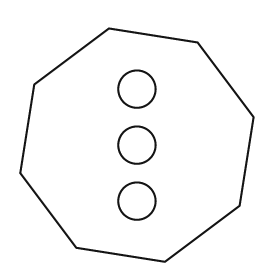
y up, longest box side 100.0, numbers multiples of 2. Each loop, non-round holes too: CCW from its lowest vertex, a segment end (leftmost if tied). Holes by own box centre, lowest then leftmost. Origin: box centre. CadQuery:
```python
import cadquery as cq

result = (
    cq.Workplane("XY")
    .moveTo(12.0, -50.0)
    .lineTo(44.0, -26.0)
    .lineTo(50.0, 12.0)
    .lineTo(26.0, 44.0)
    .lineTo(-12.0, 50.0)
    .lineTo(-44.0, 26.0)
    .lineTo(-50.0, -12.0)
    .lineTo(-26.0, -44.0)
    .close()
    .moveTo(0.0, -24.0)
    .circle(8.0)
    .moveTo(0.0, 0.0)
    .circle(8.0)
    .moveTo(0.0, 24.0)
    .circle(8.0)
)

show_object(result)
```